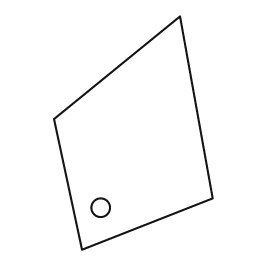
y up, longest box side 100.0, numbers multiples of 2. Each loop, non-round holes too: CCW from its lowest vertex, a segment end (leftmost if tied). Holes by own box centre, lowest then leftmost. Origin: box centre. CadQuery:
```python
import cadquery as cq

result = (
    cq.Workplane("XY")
    .moveTo(-22.0, -50.0)
    .lineTo(34.0, -28.0)
    .lineTo(20.0, 50.0)
    .lineTo(-34.0, 6.0)
    .close()
    .moveTo(-14.0, -32.0)
    .circle(4.0)
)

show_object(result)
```